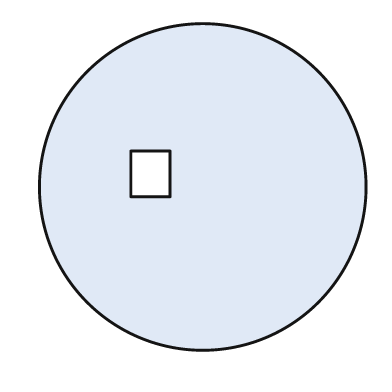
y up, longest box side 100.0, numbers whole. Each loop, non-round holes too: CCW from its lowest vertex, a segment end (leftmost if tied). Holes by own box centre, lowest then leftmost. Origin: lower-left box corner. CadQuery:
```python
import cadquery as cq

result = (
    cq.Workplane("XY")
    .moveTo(50.0, 50.0)
    .circle(50.0)
    .moveTo(28.0, 47.0)
    .lineTo(40.0, 47.0)
    .lineTo(40.0, 61.0)
    .lineTo(28.0, 61.0)
    .close()
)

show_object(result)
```